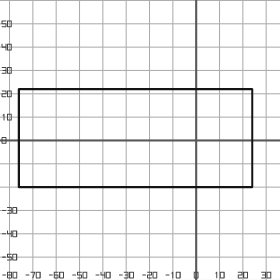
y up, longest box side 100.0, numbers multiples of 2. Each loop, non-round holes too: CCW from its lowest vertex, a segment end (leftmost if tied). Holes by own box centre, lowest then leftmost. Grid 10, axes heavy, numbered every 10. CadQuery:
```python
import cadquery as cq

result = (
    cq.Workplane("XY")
    .moveTo(-76.0, -20.0)
    .lineTo(24.0, -20.0)
    .lineTo(24.0, 22.0)
    .lineTo(-76.0, 22.0)
    .close()
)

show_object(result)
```